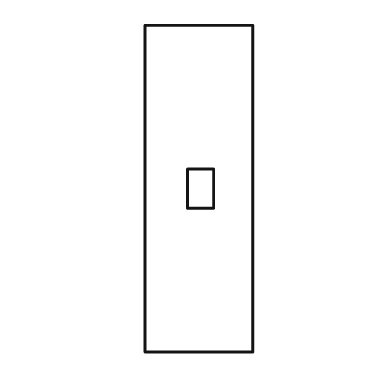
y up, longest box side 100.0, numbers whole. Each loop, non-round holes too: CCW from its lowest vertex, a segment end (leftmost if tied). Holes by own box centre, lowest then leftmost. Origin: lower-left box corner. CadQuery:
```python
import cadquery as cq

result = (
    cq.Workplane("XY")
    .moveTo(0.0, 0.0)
    .lineTo(33.0, 0.0)
    .lineTo(33.0, 100.0)
    .lineTo(0.0, 100.0)
    .close()
    .moveTo(13.0, 44.0)
    .lineTo(21.0, 44.0)
    .lineTo(21.0, 56.0)
    .lineTo(13.0, 56.0)
    .close()
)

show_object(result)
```